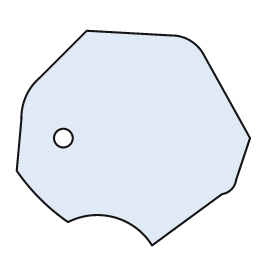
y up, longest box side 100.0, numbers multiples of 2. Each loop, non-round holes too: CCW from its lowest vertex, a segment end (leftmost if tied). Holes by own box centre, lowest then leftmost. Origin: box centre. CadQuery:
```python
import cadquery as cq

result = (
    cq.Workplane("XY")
    .moveTo(8.0, -46.0)
    .lineTo(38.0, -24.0)
    .threePointArc((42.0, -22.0), (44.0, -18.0))
    .lineTo(50.0, 0.0)
    .lineTo(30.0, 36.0)
    .threePointArc((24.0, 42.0), (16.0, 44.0))
    .lineTo(-20.0, 46.0)
    .lineTo(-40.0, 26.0)
    .threePointArc((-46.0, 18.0), (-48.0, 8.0))
    .lineTo(-50.0, -14.0)
    .threePointArc((-40.0, -26.0), (-28.0, -36.0))
    .threePointArc((-8.0, -34.0), (8.0, -46.0))
    .close()
    .moveTo(-30.0, 0.0)
    .circle(4.0)
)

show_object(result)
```